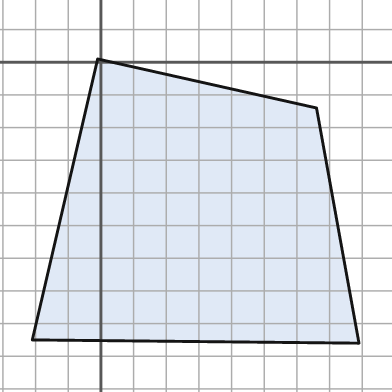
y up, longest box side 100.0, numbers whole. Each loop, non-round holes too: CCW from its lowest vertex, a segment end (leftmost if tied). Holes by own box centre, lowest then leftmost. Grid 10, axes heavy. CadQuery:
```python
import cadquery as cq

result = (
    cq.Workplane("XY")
    .moveTo(79.0, -86.0)
    .lineTo(66.0, -14.0)
    .lineTo(-1.0, 1.0)
    .lineTo(-21.0, -85.0)
    .close()
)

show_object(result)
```